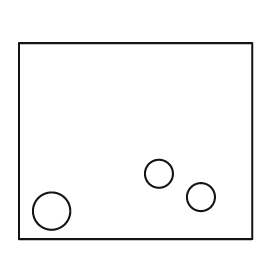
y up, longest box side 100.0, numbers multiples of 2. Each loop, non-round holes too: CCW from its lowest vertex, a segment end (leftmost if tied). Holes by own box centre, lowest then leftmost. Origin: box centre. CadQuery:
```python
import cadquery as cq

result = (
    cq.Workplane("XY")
    .moveTo(-50.0, -42.0)
    .lineTo(50.0, -42.0)
    .lineTo(50.0, 42.0)
    .lineTo(-50.0, 42.0)
    .close()
    .moveTo(-36.0, -30.0)
    .circle(8.0)
    .moveTo(28.0, -24.0)
    .circle(6.0)
    .moveTo(10.0, -14.0)
    .circle(6.0)
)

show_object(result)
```